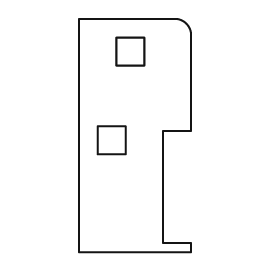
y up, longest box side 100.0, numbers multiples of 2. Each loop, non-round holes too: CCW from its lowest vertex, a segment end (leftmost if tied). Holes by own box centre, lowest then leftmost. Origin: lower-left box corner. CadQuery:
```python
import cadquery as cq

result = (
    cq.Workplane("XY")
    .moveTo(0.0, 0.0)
    .lineTo(48.0, 0.0)
    .lineTo(48.0, 4.0)
    .lineTo(36.0, 4.0)
    .lineTo(36.0, 52.0)
    .lineTo(48.0, 52.0)
    .lineTo(48.0, 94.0)
    .threePointArc((46.0, 98.0), (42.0, 100.0))
    .lineTo(0.0, 100.0)
    .close()
    .moveTo(8.0, 42.0)
    .lineTo(20.0, 42.0)
    .lineTo(20.0, 54.0)
    .lineTo(8.0, 54.0)
    .close()
    .moveTo(16.0, 80.0)
    .lineTo(28.0, 80.0)
    .lineTo(28.0, 92.0)
    .lineTo(16.0, 92.0)
    .close()
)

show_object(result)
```